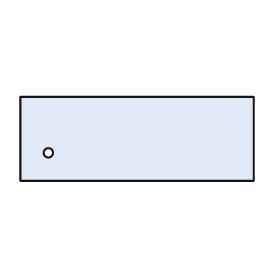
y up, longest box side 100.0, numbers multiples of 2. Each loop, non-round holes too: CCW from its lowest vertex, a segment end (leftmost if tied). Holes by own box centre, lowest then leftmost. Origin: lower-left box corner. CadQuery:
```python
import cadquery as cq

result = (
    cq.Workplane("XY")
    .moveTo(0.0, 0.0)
    .lineTo(100.0, 0.0)
    .lineTo(100.0, 36.0)
    .lineTo(0.0, 36.0)
    .close()
    .moveTo(12.0, 12.0)
    .circle(2.0)
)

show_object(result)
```